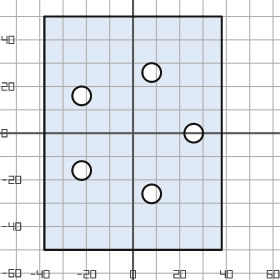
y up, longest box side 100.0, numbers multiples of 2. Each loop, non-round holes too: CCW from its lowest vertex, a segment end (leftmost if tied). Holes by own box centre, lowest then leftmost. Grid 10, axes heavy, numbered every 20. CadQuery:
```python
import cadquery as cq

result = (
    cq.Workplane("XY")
    .moveTo(-38.0, -50.0)
    .lineTo(38.0, -50.0)
    .lineTo(38.0, 50.0)
    .lineTo(-38.0, 50.0)
    .close()
    .moveTo(8.0, -26.0)
    .circle(4.0)
    .moveTo(-22.0, -16.0)
    .circle(4.0)
    .moveTo(26.0, 0.0)
    .circle(4.0)
    .moveTo(-22.0, 16.0)
    .circle(4.0)
    .moveTo(8.0, 26.0)
    .circle(4.0)
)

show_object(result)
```